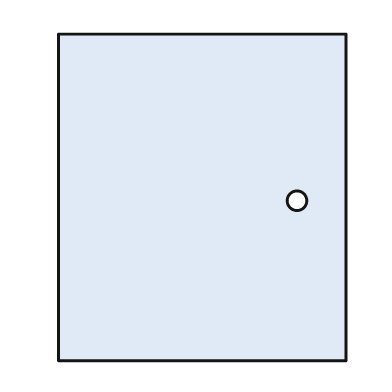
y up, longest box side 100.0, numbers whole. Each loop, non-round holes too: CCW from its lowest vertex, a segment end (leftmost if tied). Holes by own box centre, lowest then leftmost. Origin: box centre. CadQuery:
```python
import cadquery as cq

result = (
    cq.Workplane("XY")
    .moveTo(-44.0, -50.0)
    .lineTo(44.0, -50.0)
    .lineTo(44.0, 50.0)
    .lineTo(-44.0, 50.0)
    .close()
    .moveTo(29.0, -1.0)
    .circle(3.0)
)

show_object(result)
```